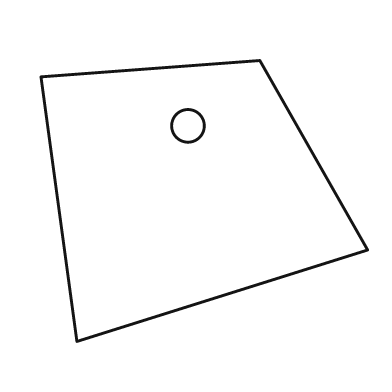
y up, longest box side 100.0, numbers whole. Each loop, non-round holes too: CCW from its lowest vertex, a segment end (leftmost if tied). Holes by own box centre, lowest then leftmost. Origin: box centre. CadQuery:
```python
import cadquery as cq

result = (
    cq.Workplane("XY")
    .moveTo(-39.0, -43.0)
    .lineTo(50.0, -15.0)
    .lineTo(17.0, 43.0)
    .lineTo(-50.0, 38.0)
    .close()
    .moveTo(-5.0, 23.0)
    .circle(5.0)
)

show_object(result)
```